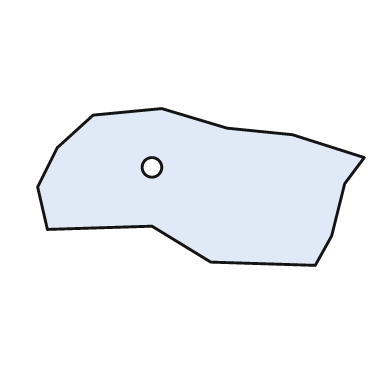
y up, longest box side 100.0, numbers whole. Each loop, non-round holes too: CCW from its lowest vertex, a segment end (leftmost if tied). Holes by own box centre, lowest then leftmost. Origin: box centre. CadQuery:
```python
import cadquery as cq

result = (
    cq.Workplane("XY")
    .moveTo(35.0, -24.0)
    .lineTo(40.0, -15.0)
    .lineTo(44.0, 1.0)
    .lineTo(50.0, 9.0)
    .lineTo(28.0, 16.0)
    .lineTo(8.0, 18.0)
    .lineTo(-12.0, 24.0)
    .lineTo(-33.0, 22.0)
    .lineTo(-44.0, 12.0)
    .lineTo(-50.0, 0.0)
    .lineTo(-47.0, -13.0)
    .lineTo(-15.0, -12.0)
    .lineTo(3.0, -23.0)
    .close()
    .moveTo(-15.0, 6.0)
    .circle(3.0)
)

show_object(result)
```